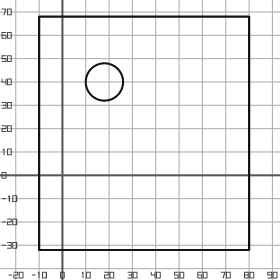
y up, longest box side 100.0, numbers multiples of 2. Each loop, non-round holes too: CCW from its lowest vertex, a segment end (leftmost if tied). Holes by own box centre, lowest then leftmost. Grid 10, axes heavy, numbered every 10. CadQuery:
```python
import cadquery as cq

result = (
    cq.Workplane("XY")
    .moveTo(-10.0, -32.0)
    .lineTo(80.0, -32.0)
    .lineTo(80.0, 68.0)
    .lineTo(-10.0, 68.0)
    .close()
    .moveTo(18.0, 40.0)
    .circle(8.0)
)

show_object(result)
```